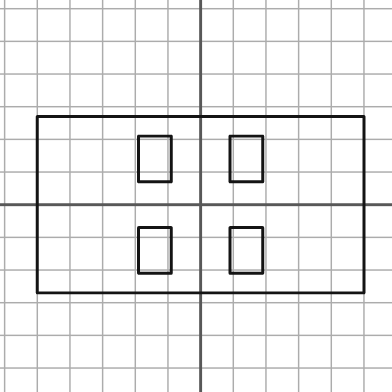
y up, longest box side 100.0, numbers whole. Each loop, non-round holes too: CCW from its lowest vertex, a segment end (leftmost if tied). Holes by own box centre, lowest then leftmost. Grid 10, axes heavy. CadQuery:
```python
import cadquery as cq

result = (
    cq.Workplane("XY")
    .moveTo(-50.0, -27.0)
    .lineTo(50.0, -27.0)
    .lineTo(50.0, 27.0)
    .lineTo(-50.0, 27.0)
    .close()
    .moveTo(-19.0, -21.0)
    .lineTo(-9.0, -21.0)
    .lineTo(-9.0, -7.0)
    .lineTo(-19.0, -7.0)
    .close()
    .moveTo(9.0, -21.0)
    .lineTo(19.0, -21.0)
    .lineTo(19.0, -7.0)
    .lineTo(9.0, -7.0)
    .close()
    .moveTo(-19.0, 7.0)
    .lineTo(-9.0, 7.0)
    .lineTo(-9.0, 21.0)
    .lineTo(-19.0, 21.0)
    .close()
    .moveTo(9.0, 7.0)
    .lineTo(19.0, 7.0)
    .lineTo(19.0, 21.0)
    .lineTo(9.0, 21.0)
    .close()
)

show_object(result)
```